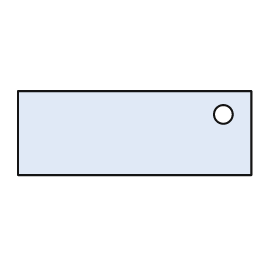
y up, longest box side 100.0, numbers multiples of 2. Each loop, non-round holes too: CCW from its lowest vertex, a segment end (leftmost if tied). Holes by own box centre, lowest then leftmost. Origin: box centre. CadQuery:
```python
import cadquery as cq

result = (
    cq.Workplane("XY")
    .moveTo(-50.0, -18.0)
    .lineTo(50.0, -18.0)
    .lineTo(50.0, 18.0)
    .lineTo(-50.0, 18.0)
    .close()
    .moveTo(38.0, 8.0)
    .circle(4.0)
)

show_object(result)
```